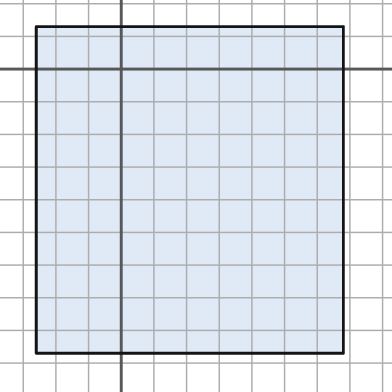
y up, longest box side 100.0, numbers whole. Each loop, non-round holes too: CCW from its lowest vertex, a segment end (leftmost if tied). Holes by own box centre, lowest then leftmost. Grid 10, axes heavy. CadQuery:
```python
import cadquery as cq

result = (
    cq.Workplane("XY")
    .moveTo(-26.0, -87.0)
    .lineTo(68.0, -87.0)
    .lineTo(68.0, 13.0)
    .lineTo(-26.0, 13.0)
    .close()
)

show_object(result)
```